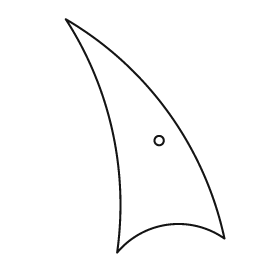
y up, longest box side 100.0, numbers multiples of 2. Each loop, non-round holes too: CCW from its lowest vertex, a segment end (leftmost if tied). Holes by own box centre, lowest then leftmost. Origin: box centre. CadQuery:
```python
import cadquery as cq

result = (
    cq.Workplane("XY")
    .moveTo(-12.0, -50.0)
    .threePointArc((10.0, -38.0), (34.0, -44.0))
    .threePointArc((10.0, 10.0), (-34.0, 50.0))
    .threePointArc((-14.0, 2.0), (-12.0, -50.0))
    .close()
    .moveTo(6.0, -2.0)
    .circle(2.0)
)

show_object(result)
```